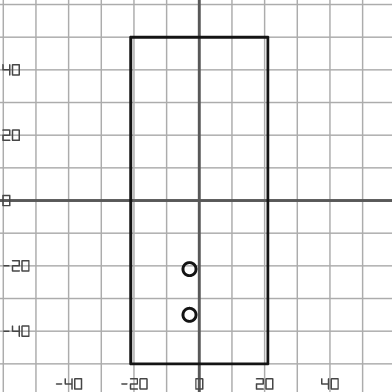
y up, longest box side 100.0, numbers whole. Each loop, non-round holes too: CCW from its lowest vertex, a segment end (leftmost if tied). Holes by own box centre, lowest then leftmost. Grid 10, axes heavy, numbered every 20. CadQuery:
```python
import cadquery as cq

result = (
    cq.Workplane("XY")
    .moveTo(-21.0, -50.0)
    .lineTo(21.0, -50.0)
    .lineTo(21.0, 50.0)
    .lineTo(-21.0, 50.0)
    .close()
    .moveTo(-3.0, -35.0)
    .circle(2.0)
    .moveTo(-3.0, -21.0)
    .circle(2.0)
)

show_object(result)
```